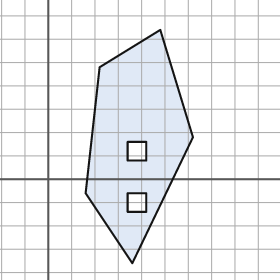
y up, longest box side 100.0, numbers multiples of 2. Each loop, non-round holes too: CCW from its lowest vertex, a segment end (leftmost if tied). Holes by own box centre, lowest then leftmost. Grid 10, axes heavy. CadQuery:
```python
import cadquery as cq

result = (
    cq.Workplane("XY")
    .moveTo(36.0, -36.0)
    .lineTo(62.0, 18.0)
    .lineTo(48.0, 64.0)
    .lineTo(22.0, 48.0)
    .lineTo(16.0, -6.0)
    .close()
    .moveTo(34.0, -14.0)
    .lineTo(42.0, -14.0)
    .lineTo(42.0, -6.0)
    .lineTo(34.0, -6.0)
    .close()
    .moveTo(34.0, 8.0)
    .lineTo(42.0, 8.0)
    .lineTo(42.0, 16.0)
    .lineTo(34.0, 16.0)
    .close()
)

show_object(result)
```